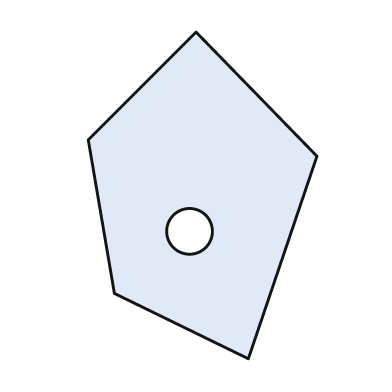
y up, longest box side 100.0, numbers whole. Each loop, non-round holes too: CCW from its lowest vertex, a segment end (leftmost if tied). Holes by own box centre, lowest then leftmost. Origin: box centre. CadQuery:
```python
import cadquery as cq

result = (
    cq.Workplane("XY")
    .moveTo(14.0, -50.0)
    .lineTo(35.0, 12.0)
    .lineTo(-2.0, 50.0)
    .lineTo(-35.0, 17.0)
    .lineTo(-27.0, -30.0)
    .close()
    .moveTo(-4.0, -11.0)
    .circle(7.0)
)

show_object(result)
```